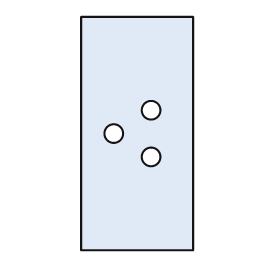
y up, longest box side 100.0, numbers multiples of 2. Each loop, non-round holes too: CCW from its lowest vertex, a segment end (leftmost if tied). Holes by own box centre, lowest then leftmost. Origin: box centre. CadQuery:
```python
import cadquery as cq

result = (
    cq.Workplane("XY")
    .moveTo(-24.0, -50.0)
    .lineTo(24.0, -50.0)
    .lineTo(24.0, 50.0)
    .lineTo(-24.0, 50.0)
    .close()
    .moveTo(6.0, -10.0)
    .circle(4.0)
    .moveTo(-10.0, 0.0)
    .circle(4.0)
    .moveTo(6.0, 10.0)
    .circle(4.0)
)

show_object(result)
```